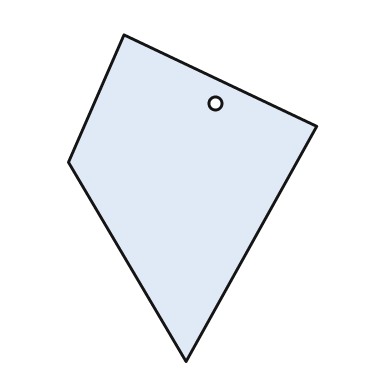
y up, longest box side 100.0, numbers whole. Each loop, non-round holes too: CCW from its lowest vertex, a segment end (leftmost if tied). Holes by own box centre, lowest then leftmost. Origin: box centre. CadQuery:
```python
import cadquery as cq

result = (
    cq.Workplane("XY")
    .moveTo(-2.0, -50.0)
    .lineTo(38.0, 22.0)
    .lineTo(-21.0, 50.0)
    .lineTo(-38.0, 11.0)
    .close()
    .moveTo(7.0, 29.0)
    .circle(2.0)
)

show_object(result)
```